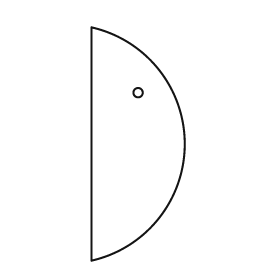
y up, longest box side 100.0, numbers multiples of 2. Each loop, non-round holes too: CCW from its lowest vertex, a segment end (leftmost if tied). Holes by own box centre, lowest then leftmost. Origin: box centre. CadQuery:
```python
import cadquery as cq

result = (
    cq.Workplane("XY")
    .moveTo(-20.0, -50.0)
    .threePointArc((20.0, 0.0), (-20.0, 50.0))
    .close()
    .moveTo(0.0, 22.0)
    .circle(2.0)
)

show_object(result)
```